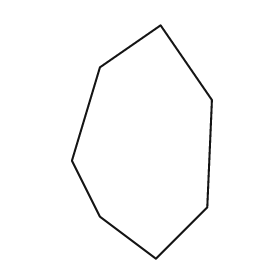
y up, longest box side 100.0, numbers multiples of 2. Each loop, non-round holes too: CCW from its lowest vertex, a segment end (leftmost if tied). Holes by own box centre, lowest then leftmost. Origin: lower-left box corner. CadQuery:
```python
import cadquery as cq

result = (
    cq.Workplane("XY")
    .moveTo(36.0, 0.0)
    .lineTo(58.0, 22.0)
    .lineTo(60.0, 68.0)
    .lineTo(38.0, 100.0)
    .lineTo(12.0, 82.0)
    .lineTo(0.0, 42.0)
    .lineTo(12.0, 18.0)
    .close()
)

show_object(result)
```